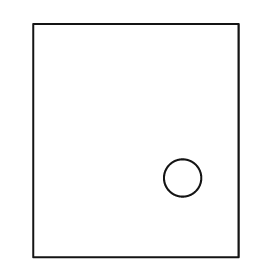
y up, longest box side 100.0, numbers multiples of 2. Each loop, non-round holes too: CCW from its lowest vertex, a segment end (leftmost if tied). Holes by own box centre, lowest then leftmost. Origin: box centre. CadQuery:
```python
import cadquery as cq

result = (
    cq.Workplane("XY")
    .moveTo(-44.0, -50.0)
    .lineTo(44.0, -50.0)
    .lineTo(44.0, 50.0)
    .lineTo(-44.0, 50.0)
    .close()
    .moveTo(20.0, -16.0)
    .circle(8.0)
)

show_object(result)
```